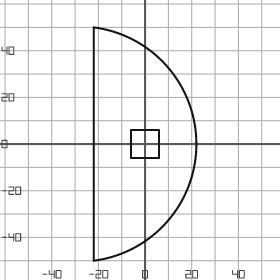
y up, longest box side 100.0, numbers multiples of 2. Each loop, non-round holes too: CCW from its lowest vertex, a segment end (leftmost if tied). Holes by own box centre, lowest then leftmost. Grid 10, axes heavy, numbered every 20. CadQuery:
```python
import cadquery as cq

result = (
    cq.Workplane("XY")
    .moveTo(-22.0, -50.0)
    .threePointArc((22.0, 0.0), (-22.0, 50.0))
    .close()
    .moveTo(-6.0, -6.0)
    .lineTo(6.0, -6.0)
    .lineTo(6.0, 6.0)
    .lineTo(-6.0, 6.0)
    .close()
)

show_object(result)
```